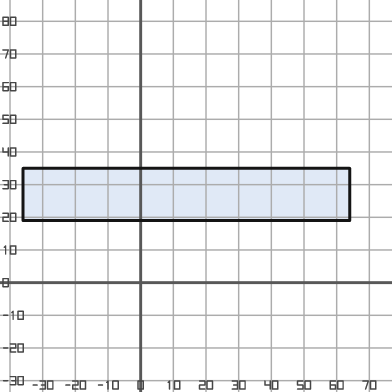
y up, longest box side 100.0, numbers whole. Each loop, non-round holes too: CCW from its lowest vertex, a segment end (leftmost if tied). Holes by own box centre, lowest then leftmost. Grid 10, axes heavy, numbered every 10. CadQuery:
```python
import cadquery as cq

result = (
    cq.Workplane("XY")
    .moveTo(-36.0, 19.0)
    .lineTo(64.0, 19.0)
    .lineTo(64.0, 35.0)
    .lineTo(-36.0, 35.0)
    .close()
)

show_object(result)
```